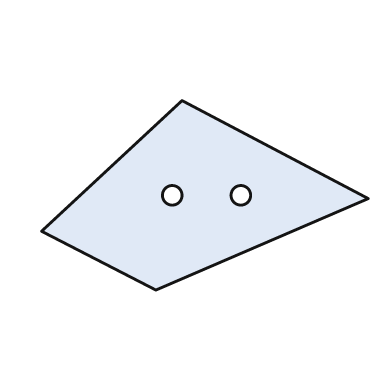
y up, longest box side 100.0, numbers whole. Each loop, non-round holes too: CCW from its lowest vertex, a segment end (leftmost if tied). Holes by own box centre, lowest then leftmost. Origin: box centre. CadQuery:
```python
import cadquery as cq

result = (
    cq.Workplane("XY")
    .moveTo(-15.0, -29.0)
    .lineTo(50.0, -1.0)
    .lineTo(-7.0, 29.0)
    .lineTo(-50.0, -11.0)
    .close()
    .moveTo(-10.0, 0.0)
    .circle(3.0)
    .moveTo(11.0, 0.0)
    .circle(3.0)
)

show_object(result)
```